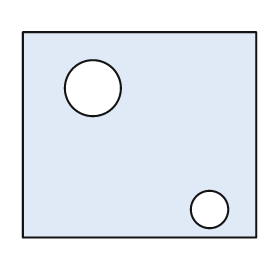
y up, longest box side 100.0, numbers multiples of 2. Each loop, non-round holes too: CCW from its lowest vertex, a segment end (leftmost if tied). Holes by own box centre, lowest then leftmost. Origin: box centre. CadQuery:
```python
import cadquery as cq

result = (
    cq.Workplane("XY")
    .moveTo(-50.0, -44.0)
    .lineTo(50.0, -44.0)
    .lineTo(50.0, 44.0)
    .lineTo(-50.0, 44.0)
    .close()
    .moveTo(30.0, -32.0)
    .circle(8.0)
    .moveTo(-20.0, 20.0)
    .circle(12.0)
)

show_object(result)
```